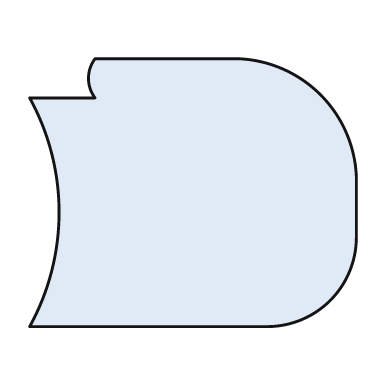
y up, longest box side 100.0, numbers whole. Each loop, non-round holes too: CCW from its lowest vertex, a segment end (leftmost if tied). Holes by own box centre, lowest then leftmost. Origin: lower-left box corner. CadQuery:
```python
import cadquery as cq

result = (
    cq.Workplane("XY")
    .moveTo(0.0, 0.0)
    .lineTo(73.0, 0.0)
    .threePointArc((92.0, 8.0), (100.0, 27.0))
    .lineTo(100.0, 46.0)
    .threePointArc((89.0, 71.0), (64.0, 82.0))
    .lineTo(20.0, 82.0)
    .threePointArc((18.0, 76.0), (20.0, 70.0))
    .lineTo(0.0, 70.0)
    .threePointArc((9.0, 35.0), (0.0, 0.0))
    .close()
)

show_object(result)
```